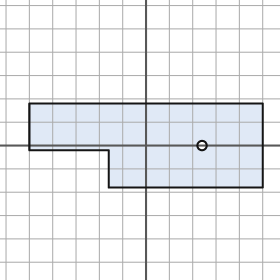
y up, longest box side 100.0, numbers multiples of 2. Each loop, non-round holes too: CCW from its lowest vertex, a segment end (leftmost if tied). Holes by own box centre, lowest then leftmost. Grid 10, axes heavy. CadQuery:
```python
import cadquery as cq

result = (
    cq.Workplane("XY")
    .moveTo(-16.0, -18.0)
    .lineTo(50.0, -18.0)
    .lineTo(50.0, 18.0)
    .lineTo(-50.0, 18.0)
    .lineTo(-50.0, -2.0)
    .lineTo(-16.0, -2.0)
    .close()
    .moveTo(24.0, 0.0)
    .circle(2.0)
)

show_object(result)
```